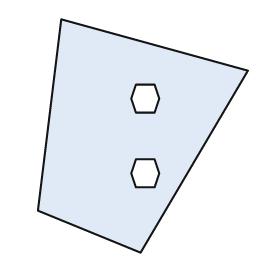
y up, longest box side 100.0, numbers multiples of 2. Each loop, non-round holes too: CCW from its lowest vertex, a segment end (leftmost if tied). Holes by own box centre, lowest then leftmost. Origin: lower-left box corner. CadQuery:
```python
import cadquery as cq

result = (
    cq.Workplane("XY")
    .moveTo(44.0, 0.0)
    .lineTo(90.0, 78.0)
    .lineTo(10.0, 100.0)
    .lineTo(0.0, 18.0)
    .close()
    .moveTo(42.0, 28.0)
    .lineTo(50.0, 28.0)
    .lineTo(52.0, 34.0)
    .lineTo(50.0, 40.0)
    .lineTo(42.0, 40.0)
    .lineTo(40.0, 34.0)
    .close()
    .moveTo(42.0, 60.0)
    .lineTo(50.0, 60.0)
    .lineTo(52.0, 66.0)
    .lineTo(50.0, 72.0)
    .lineTo(42.0, 72.0)
    .lineTo(40.0, 66.0)
    .close()
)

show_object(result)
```